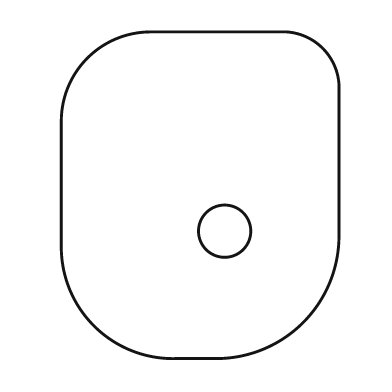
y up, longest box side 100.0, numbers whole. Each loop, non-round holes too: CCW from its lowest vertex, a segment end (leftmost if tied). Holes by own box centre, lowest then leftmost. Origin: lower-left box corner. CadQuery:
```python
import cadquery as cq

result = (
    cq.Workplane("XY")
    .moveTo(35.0, 0.0)
    .lineTo(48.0, 0.0)
    .threePointArc((74.0, 11.0), (85.0, 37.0))
    .lineTo(85.0, 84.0)
    .threePointArc((80.0, 95.0), (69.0, 100.0))
    .lineTo(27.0, 100.0)
    .threePointArc((8.0, 92.0), (0.0, 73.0))
    .lineTo(0.0, 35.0)
    .threePointArc((10.0, 10.0), (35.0, 0.0))
    .close()
    .moveTo(50.0, 39.0)
    .circle(8.0)
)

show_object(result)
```